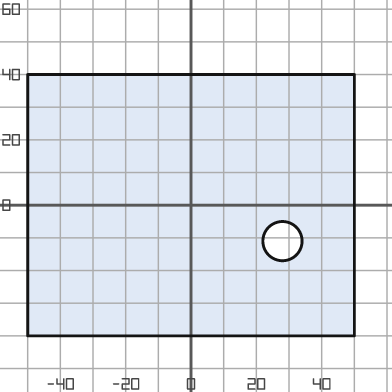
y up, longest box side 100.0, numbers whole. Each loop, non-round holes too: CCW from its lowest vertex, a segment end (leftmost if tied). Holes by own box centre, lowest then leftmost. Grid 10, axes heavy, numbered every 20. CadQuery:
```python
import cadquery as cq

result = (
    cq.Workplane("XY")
    .moveTo(-50.0, -40.0)
    .lineTo(50.0, -40.0)
    .lineTo(50.0, 40.0)
    .lineTo(-50.0, 40.0)
    .close()
    .moveTo(28.0, -11.0)
    .circle(6.0)
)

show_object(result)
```